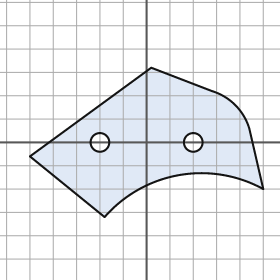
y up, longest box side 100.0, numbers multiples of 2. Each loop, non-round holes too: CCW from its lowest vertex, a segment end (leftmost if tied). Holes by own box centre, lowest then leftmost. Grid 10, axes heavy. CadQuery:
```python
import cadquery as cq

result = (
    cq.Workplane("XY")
    .moveTo(-18.0, -32.0)
    .threePointArc((14.0, -14.0), (50.0, -20.0))
    .lineTo(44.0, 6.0)
    .threePointArc((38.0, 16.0), (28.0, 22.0))
    .lineTo(2.0, 32.0)
    .lineTo(-50.0, -6.0)
    .close()
    .moveTo(-20.0, 0.0)
    .circle(4.0)
    .moveTo(20.0, 0.0)
    .circle(4.0)
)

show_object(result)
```